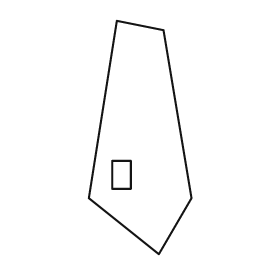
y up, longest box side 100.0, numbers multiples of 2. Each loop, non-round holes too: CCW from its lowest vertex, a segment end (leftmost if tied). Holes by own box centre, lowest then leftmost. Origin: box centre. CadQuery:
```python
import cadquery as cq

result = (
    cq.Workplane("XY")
    .moveTo(8.0, -50.0)
    .lineTo(22.0, -26.0)
    .lineTo(10.0, 46.0)
    .lineTo(-10.0, 50.0)
    .lineTo(-22.0, -26.0)
    .close()
    .moveTo(-12.0, -22.0)
    .lineTo(-4.0, -22.0)
    .lineTo(-4.0, -10.0)
    .lineTo(-12.0, -10.0)
    .close()
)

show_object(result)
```